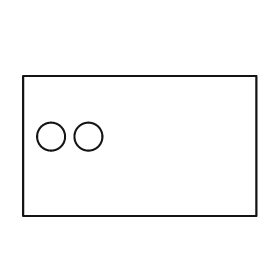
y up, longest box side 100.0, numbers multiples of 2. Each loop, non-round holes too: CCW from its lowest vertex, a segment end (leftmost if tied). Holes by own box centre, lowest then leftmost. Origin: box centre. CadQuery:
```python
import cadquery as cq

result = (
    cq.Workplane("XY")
    .moveTo(-50.0, -30.0)
    .lineTo(50.0, -30.0)
    .lineTo(50.0, 30.0)
    .lineTo(-50.0, 30.0)
    .close()
    .moveTo(-38.0, 4.0)
    .circle(6.0)
    .moveTo(-22.0, 4.0)
    .circle(6.0)
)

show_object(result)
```